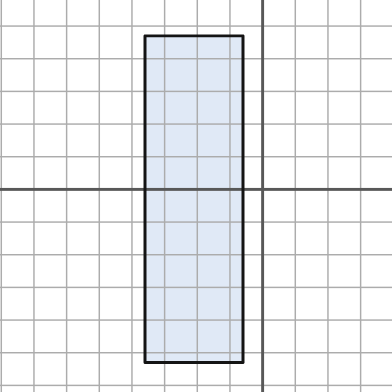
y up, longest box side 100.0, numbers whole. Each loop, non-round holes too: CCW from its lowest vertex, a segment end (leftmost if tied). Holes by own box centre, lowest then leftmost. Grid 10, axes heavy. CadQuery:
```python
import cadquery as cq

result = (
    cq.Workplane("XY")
    .moveTo(-36.0, -53.0)
    .lineTo(-6.0, -53.0)
    .lineTo(-6.0, 47.0)
    .lineTo(-36.0, 47.0)
    .close()
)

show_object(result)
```